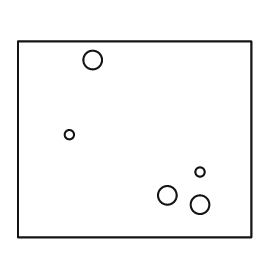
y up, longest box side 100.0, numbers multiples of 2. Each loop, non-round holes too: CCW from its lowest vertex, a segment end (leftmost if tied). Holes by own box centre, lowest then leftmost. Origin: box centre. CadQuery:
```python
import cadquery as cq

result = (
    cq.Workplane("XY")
    .moveTo(-50.0, -42.0)
    .lineTo(50.0, -42.0)
    .lineTo(50.0, 42.0)
    .lineTo(-50.0, 42.0)
    .close()
    .moveTo(28.0, -28.0)
    .circle(4.0)
    .moveTo(14.0, -24.0)
    .circle(4.0)
    .moveTo(28.0, -14.0)
    .circle(2.0)
    .moveTo(-28.0, 2.0)
    .circle(2.0)
    .moveTo(-18.0, 34.0)
    .circle(4.0)
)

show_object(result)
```